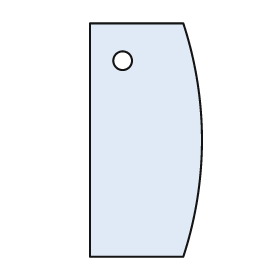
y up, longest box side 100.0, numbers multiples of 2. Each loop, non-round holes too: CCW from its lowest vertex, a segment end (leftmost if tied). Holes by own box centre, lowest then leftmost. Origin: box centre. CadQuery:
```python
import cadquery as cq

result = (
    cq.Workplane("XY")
    .moveTo(-24.0, -50.0)
    .lineTo(16.0, -50.0)
    .threePointArc((24.0, 0.0), (16.0, 50.0))
    .lineTo(-24.0, 50.0)
    .close()
    .moveTo(-10.0, 34.0)
    .circle(4.0)
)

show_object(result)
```